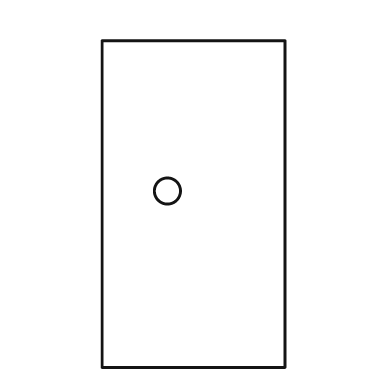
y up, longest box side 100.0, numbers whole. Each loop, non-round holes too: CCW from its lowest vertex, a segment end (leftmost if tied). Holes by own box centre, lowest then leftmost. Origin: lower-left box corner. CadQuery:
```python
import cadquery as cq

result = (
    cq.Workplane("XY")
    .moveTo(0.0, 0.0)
    .lineTo(56.0, 0.0)
    .lineTo(56.0, 100.0)
    .lineTo(0.0, 100.0)
    .close()
    .moveTo(20.0, 54.0)
    .circle(4.0)
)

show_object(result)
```